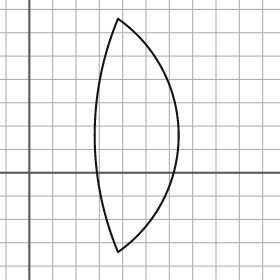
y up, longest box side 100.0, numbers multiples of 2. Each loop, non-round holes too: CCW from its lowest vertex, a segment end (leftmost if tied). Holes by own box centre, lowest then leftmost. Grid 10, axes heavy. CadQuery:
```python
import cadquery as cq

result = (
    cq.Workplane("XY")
    .moveTo(38.0, -34.0)
    .threePointArc((64.0, 16.0), (38.0, 66.0))
    .threePointArc((28.0, 16.0), (38.0, -34.0))
    .close()
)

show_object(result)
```